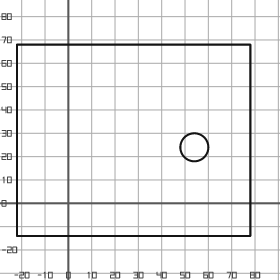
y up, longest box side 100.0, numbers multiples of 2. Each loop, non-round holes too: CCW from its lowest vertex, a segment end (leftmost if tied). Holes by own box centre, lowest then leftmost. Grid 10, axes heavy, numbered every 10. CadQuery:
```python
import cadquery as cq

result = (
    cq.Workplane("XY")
    .moveTo(-22.0, -14.0)
    .lineTo(78.0, -14.0)
    .lineTo(78.0, 68.0)
    .lineTo(-22.0, 68.0)
    .close()
    .moveTo(54.0, 24.0)
    .circle(6.0)
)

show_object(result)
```